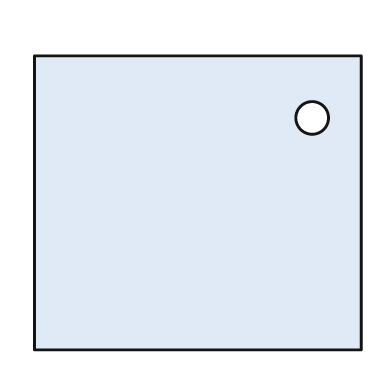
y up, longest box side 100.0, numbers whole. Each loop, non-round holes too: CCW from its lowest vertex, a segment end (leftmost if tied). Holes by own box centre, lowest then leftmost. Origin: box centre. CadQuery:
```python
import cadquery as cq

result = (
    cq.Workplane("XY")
    .moveTo(-50.0, -45.0)
    .lineTo(50.0, -45.0)
    .lineTo(50.0, 45.0)
    .lineTo(-50.0, 45.0)
    .close()
    .moveTo(35.0, 26.0)
    .circle(5.0)
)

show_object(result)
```